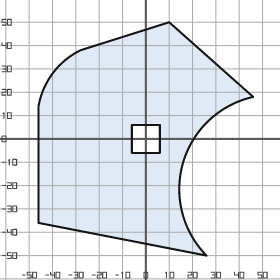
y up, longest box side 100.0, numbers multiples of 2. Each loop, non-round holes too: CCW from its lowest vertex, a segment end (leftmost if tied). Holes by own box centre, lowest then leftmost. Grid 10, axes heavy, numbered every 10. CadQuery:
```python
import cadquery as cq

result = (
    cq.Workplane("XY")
    .moveTo(26.0, -50.0)
    .threePointArc((16.0, -10.0), (46.0, 18.0))
    .lineTo(10.0, 50.0)
    .lineTo(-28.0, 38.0)
    .threePointArc((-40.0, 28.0), (-46.0, 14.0))
    .lineTo(-46.0, -36.0)
    .close()
    .moveTo(-6.0, -6.0)
    .lineTo(6.0, -6.0)
    .lineTo(6.0, 6.0)
    .lineTo(-6.0, 6.0)
    .close()
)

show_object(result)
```